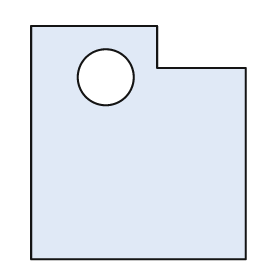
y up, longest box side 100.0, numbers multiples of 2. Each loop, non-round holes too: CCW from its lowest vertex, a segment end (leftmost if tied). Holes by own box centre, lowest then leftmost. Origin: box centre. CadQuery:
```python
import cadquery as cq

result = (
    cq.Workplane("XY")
    .moveTo(-46.0, -50.0)
    .lineTo(46.0, -50.0)
    .lineTo(46.0, 32.0)
    .lineTo(8.0, 32.0)
    .lineTo(8.0, 50.0)
    .lineTo(-46.0, 50.0)
    .close()
    .moveTo(-14.0, 28.0)
    .circle(12.0)
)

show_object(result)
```